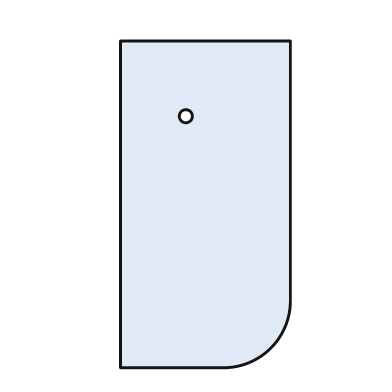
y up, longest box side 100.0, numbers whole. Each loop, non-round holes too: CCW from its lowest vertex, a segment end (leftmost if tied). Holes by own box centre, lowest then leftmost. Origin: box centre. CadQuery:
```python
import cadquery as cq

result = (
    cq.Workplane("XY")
    .moveTo(-26.0, -50.0)
    .lineTo(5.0, -50.0)
    .threePointArc((20.0, -44.0), (26.0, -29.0))
    .lineTo(26.0, 50.0)
    .lineTo(-26.0, 50.0)
    .close()
    .moveTo(-6.0, 27.0)
    .circle(2.0)
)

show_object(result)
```